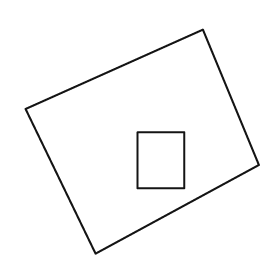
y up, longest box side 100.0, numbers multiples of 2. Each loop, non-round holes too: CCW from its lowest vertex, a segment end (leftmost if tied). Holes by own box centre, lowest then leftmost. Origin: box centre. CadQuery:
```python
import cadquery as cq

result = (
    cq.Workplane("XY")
    .moveTo(-20.0, -48.0)
    .lineTo(50.0, -10.0)
    .lineTo(26.0, 48.0)
    .lineTo(-50.0, 14.0)
    .close()
    .moveTo(-2.0, -20.0)
    .lineTo(18.0, -20.0)
    .lineTo(18.0, 4.0)
    .lineTo(-2.0, 4.0)
    .close()
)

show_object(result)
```